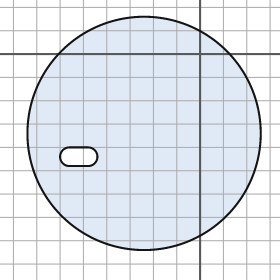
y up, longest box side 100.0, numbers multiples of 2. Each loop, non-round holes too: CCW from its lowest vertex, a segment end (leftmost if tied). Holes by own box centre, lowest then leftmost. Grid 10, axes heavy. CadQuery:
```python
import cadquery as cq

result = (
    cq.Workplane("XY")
    .moveTo(-24.0, -34.0)
    .circle(50.0)
    .moveTo(-56.0, -48.0)
    .lineTo(-48.0, -48.0)
    .threePointArc((-44.0, -44.0), (-48.0, -40.0))
    .lineTo(-56.0, -40.0)
    .threePointArc((-60.0, -44.0), (-56.0, -48.0))
    .close()
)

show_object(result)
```